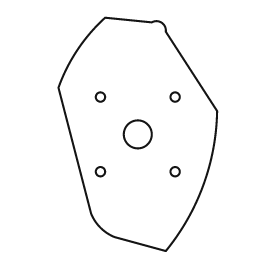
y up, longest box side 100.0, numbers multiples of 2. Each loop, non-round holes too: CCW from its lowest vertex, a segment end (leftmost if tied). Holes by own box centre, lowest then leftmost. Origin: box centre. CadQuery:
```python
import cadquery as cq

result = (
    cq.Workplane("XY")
    .moveTo(12.0, -50.0)
    .threePointArc((28.0, -22.0), (34.0, 10.0))
    .lineTo(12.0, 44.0)
    .threePointArc((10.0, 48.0), (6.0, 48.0))
    .lineTo(-14.0, 50.0)
    .threePointArc((-26.0, 36.0), (-34.0, 20.0))
    .lineTo(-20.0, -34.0)
    .threePointArc((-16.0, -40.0), (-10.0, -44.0))
    .close()
    .moveTo(-16.0, -16.0)
    .circle(2.0)
    .moveTo(16.0, -16.0)
    .circle(2.0)
    .moveTo(0.0, 0.0)
    .circle(6.0)
    .moveTo(-16.0, 16.0)
    .circle(2.0)
    .moveTo(16.0, 16.0)
    .circle(2.0)
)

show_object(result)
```